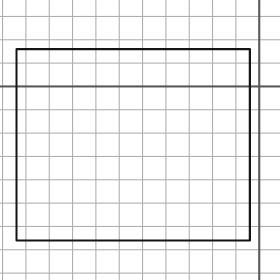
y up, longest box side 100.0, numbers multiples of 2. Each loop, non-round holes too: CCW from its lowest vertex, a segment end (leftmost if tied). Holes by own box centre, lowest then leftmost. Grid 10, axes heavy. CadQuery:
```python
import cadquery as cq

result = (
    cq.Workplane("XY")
    .moveTo(-104.0, -66.0)
    .lineTo(-4.0, -66.0)
    .lineTo(-4.0, 16.0)
    .lineTo(-104.0, 16.0)
    .close()
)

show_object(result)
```